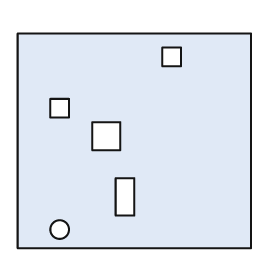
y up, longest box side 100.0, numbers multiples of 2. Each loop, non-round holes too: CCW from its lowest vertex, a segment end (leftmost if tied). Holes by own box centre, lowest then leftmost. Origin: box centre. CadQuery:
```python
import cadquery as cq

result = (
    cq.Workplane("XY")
    .moveTo(-50.0, -46.0)
    .lineTo(50.0, -46.0)
    .lineTo(50.0, 46.0)
    .lineTo(-50.0, 46.0)
    .close()
    .moveTo(-32.0, -38.0)
    .circle(4.0)
    .moveTo(-8.0, -32.0)
    .lineTo(0.0, -32.0)
    .lineTo(0.0, -16.0)
    .lineTo(-8.0, -16.0)
    .close()
    .moveTo(-18.0, -4.0)
    .lineTo(-6.0, -4.0)
    .lineTo(-6.0, 8.0)
    .lineTo(-18.0, 8.0)
    .close()
    .moveTo(-36.0, 10.0)
    .lineTo(-28.0, 10.0)
    .lineTo(-28.0, 18.0)
    .lineTo(-36.0, 18.0)
    .close()
    .moveTo(12.0, 32.0)
    .lineTo(20.0, 32.0)
    .lineTo(20.0, 40.0)
    .lineTo(12.0, 40.0)
    .close()
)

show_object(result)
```